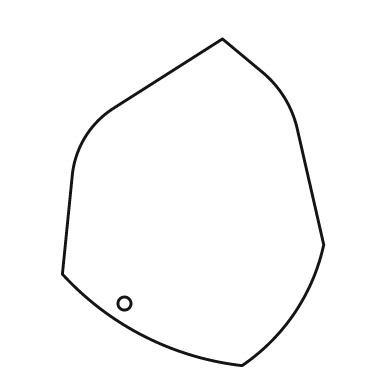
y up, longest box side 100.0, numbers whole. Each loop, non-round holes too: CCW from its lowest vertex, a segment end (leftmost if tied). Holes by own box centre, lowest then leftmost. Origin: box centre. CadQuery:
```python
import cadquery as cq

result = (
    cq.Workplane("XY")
    .moveTo(15.0, -50.0)
    .threePointArc((31.0, -34.0), (40.0, -13.0))
    .lineTo(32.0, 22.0)
    .threePointArc((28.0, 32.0), (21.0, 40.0))
    .lineTo(9.0, 50.0)
    .lineTo(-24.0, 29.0)
    .threePointArc((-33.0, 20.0), (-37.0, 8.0))
    .lineTo(-40.0, -22.0)
    .threePointArc((-15.0, -41.0), (15.0, -50.0))
    .close()
    .moveTo(-21.0, -31.0)
    .circle(2.0)
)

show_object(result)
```